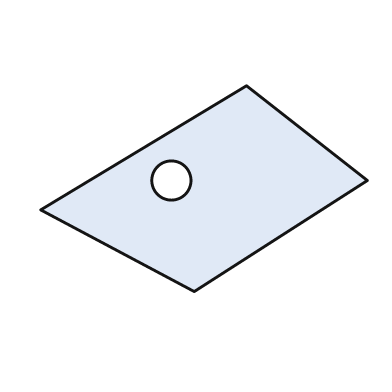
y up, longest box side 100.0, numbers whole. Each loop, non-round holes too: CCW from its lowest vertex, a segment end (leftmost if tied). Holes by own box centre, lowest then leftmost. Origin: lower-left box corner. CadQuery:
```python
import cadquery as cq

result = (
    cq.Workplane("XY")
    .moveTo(47.0, 0.0)
    .lineTo(100.0, 34.0)
    .lineTo(63.0, 63.0)
    .lineTo(0.0, 25.0)
    .close()
    .moveTo(40.0, 34.0)
    .circle(6.0)
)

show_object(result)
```